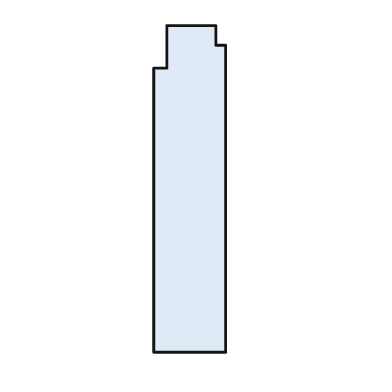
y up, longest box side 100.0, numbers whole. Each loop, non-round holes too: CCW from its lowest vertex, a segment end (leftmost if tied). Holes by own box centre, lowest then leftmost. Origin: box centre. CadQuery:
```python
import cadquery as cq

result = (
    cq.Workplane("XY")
    .moveTo(-11.0, -50.0)
    .lineTo(11.0, -50.0)
    .lineTo(11.0, 44.0)
    .lineTo(8.0, 44.0)
    .lineTo(8.0, 50.0)
    .lineTo(-7.0, 50.0)
    .lineTo(-7.0, 37.0)
    .lineTo(-11.0, 37.0)
    .close()
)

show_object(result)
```